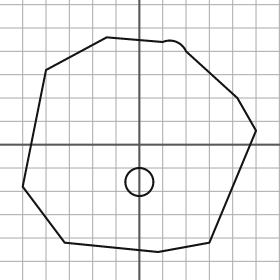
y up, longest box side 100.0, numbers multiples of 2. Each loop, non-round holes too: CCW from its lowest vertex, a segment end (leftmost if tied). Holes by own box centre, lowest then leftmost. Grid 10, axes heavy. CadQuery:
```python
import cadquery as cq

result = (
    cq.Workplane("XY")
    .moveTo(8.0, -46.0)
    .lineTo(30.0, -42.0)
    .lineTo(50.0, 6.0)
    .lineTo(42.0, 20.0)
    .lineTo(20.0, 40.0)
    .threePointArc((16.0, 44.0), (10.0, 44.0))
    .lineTo(-14.0, 46.0)
    .lineTo(-40.0, 32.0)
    .lineTo(-50.0, -18.0)
    .lineTo(-32.0, -42.0)
    .close()
    .moveTo(0.0, -16.0)
    .circle(6.0)
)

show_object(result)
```